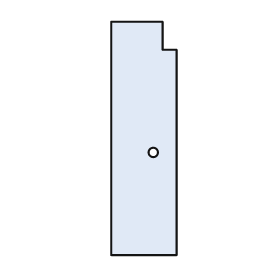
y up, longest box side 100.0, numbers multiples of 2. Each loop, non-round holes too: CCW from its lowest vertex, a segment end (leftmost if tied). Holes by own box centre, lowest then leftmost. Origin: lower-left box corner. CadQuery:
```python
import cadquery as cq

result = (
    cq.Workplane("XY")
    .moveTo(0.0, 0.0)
    .lineTo(28.0, 0.0)
    .lineTo(28.0, 88.0)
    .lineTo(22.0, 88.0)
    .lineTo(22.0, 100.0)
    .lineTo(0.0, 100.0)
    .close()
    .moveTo(18.0, 44.0)
    .circle(2.0)
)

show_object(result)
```